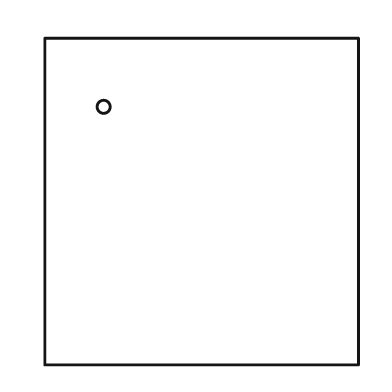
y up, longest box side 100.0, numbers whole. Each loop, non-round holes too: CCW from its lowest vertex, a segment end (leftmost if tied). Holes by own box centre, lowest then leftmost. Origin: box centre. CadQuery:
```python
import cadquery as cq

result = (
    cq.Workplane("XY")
    .moveTo(-48.0, -50.0)
    .lineTo(48.0, -50.0)
    .lineTo(48.0, 50.0)
    .lineTo(-48.0, 50.0)
    .close()
    .moveTo(-30.0, 29.0)
    .circle(2.0)
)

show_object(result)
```